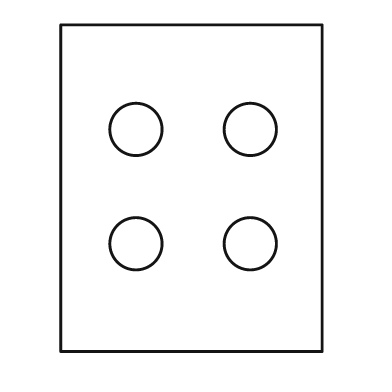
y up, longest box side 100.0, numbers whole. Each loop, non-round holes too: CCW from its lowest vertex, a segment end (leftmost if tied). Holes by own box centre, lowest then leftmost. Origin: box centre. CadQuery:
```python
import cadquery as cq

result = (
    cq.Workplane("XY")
    .moveTo(-40.0, -50.0)
    .lineTo(40.0, -50.0)
    .lineTo(40.0, 50.0)
    .lineTo(-40.0, 50.0)
    .close()
    .moveTo(-17.0, -17.0)
    .circle(8.0)
    .moveTo(18.0, -17.0)
    .circle(8.0)
    .moveTo(-17.0, 18.0)
    .circle(8.0)
    .moveTo(18.0, 18.0)
    .circle(8.0)
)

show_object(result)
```